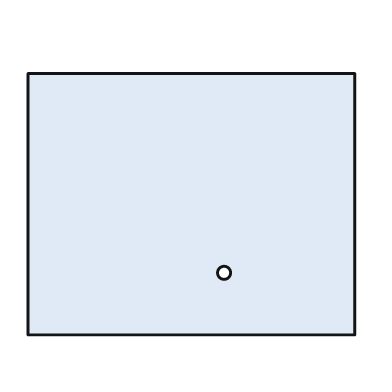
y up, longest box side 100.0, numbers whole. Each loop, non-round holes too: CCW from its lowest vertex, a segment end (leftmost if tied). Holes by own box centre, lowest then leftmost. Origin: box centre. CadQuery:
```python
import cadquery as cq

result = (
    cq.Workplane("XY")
    .moveTo(-50.0, -40.0)
    .lineTo(50.0, -40.0)
    .lineTo(50.0, 40.0)
    .lineTo(-50.0, 40.0)
    .close()
    .moveTo(10.0, -21.0)
    .circle(2.0)
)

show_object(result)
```